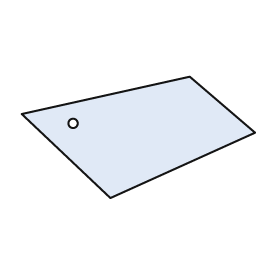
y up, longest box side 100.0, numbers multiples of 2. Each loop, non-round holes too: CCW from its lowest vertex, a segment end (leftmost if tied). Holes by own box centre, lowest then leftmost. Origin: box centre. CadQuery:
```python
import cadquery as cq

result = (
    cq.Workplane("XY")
    .moveTo(-12.0, -26.0)
    .lineTo(50.0, 2.0)
    .lineTo(22.0, 26.0)
    .lineTo(-50.0, 10.0)
    .close()
    .moveTo(-28.0, 6.0)
    .circle(2.0)
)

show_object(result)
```